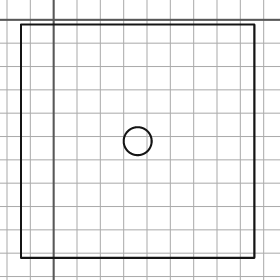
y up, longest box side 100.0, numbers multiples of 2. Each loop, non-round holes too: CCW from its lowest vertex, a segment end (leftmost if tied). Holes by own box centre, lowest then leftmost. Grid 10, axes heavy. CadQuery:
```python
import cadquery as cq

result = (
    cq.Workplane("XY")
    .moveTo(-14.0, -102.0)
    .lineTo(86.0, -102.0)
    .lineTo(86.0, -2.0)
    .lineTo(-14.0, -2.0)
    .close()
    .moveTo(36.0, -52.0)
    .circle(6.0)
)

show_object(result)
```